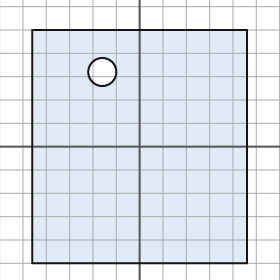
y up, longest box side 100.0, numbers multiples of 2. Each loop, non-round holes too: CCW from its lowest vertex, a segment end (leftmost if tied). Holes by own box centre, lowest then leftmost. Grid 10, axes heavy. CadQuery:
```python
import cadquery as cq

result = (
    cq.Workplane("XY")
    .moveTo(-46.0, -50.0)
    .lineTo(46.0, -50.0)
    .lineTo(46.0, 50.0)
    .lineTo(-46.0, 50.0)
    .close()
    .moveTo(-16.0, 32.0)
    .circle(6.0)
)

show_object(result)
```